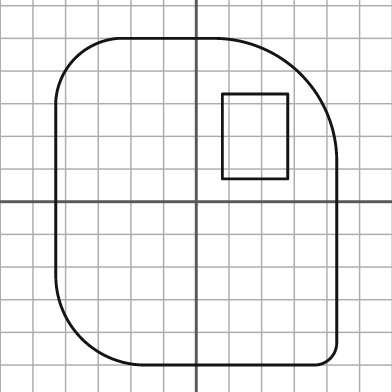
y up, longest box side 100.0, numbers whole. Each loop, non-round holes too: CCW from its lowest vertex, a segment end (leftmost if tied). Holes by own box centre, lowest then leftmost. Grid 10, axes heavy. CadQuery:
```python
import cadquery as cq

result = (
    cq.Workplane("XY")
    .moveTo(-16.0, -50.0)
    .lineTo(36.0, -50.0)
    .threePointArc((41.0, -48.0), (43.0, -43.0))
    .lineTo(43.0, 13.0)
    .threePointArc((32.0, 39.0), (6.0, 50.0))
    .lineTo(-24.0, 50.0)
    .threePointArc((-37.0, 44.0), (-43.0, 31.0))
    .lineTo(-43.0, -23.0)
    .threePointArc((-35.0, -42.0), (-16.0, -50.0))
    .close()
    .moveTo(8.0, 7.0)
    .lineTo(28.0, 7.0)
    .lineTo(28.0, 33.0)
    .lineTo(8.0, 33.0)
    .close()
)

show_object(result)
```